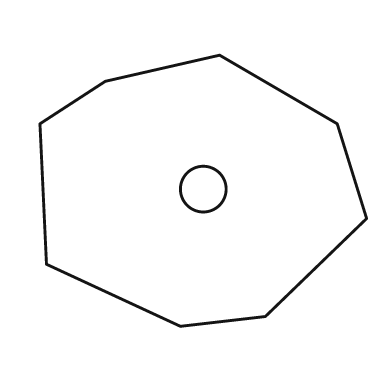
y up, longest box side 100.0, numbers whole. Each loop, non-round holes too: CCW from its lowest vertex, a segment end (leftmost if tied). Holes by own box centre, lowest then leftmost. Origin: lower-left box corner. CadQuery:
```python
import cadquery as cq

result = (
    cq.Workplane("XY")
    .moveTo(43.0, 0.0)
    .lineTo(69.0, 3.0)
    .lineTo(100.0, 33.0)
    .lineTo(91.0, 62.0)
    .lineTo(55.0, 83.0)
    .lineTo(20.0, 75.0)
    .lineTo(0.0, 62.0)
    .lineTo(2.0, 19.0)
    .close()
    .moveTo(50.0, 42.0)
    .circle(7.0)
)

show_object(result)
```